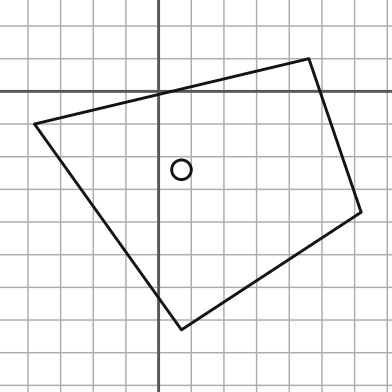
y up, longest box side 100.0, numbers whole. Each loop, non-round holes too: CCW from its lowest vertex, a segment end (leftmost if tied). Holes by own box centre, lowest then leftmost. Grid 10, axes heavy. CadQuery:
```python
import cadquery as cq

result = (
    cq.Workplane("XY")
    .moveTo(7.0, -73.0)
    .lineTo(62.0, -37.0)
    .lineTo(46.0, 10.0)
    .lineTo(-38.0, -10.0)
    .close()
    .moveTo(7.0, -24.0)
    .circle(3.0)
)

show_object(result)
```